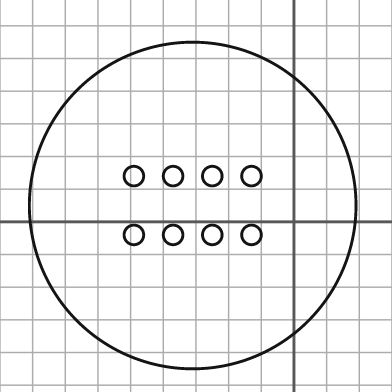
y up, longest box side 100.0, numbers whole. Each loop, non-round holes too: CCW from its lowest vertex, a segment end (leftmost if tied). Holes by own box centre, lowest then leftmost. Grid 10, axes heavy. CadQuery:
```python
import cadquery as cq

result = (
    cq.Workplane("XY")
    .moveTo(-31.0, 5.0)
    .circle(50.0)
    .moveTo(-49.0, -4.0)
    .circle(3.0)
    .moveTo(-37.0, -4.0)
    .circle(3.0)
    .moveTo(-25.0, -4.0)
    .circle(3.0)
    .moveTo(-13.0, -4.0)
    .circle(3.0)
    .moveTo(-49.0, 14.0)
    .circle(3.0)
    .moveTo(-37.0, 14.0)
    .circle(3.0)
    .moveTo(-25.0, 14.0)
    .circle(3.0)
    .moveTo(-13.0, 14.0)
    .circle(3.0)
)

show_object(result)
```